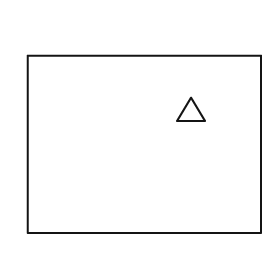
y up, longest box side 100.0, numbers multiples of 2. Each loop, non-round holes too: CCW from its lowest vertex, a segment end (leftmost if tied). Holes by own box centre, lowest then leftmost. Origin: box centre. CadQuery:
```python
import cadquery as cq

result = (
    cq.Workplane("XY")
    .moveTo(-50.0, -38.0)
    .lineTo(50.0, -38.0)
    .lineTo(50.0, 38.0)
    .lineTo(-50.0, 38.0)
    .close()
    .moveTo(14.0, 10.0)
    .lineTo(26.0, 10.0)
    .lineTo(20.0, 20.0)
    .close()
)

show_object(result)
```